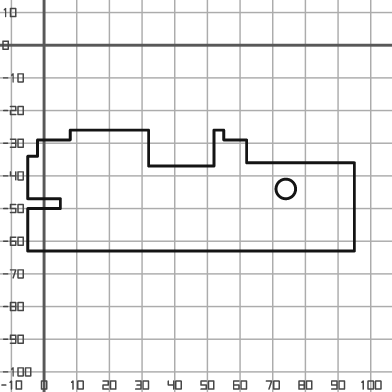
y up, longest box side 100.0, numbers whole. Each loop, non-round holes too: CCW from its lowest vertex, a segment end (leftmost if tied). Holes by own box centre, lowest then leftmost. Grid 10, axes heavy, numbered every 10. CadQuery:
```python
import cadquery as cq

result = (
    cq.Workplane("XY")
    .moveTo(-5.0, -63.0)
    .lineTo(95.0, -63.0)
    .lineTo(95.0, -36.0)
    .lineTo(62.0, -36.0)
    .lineTo(62.0, -29.0)
    .lineTo(55.0, -29.0)
    .lineTo(55.0, -26.0)
    .lineTo(52.0, -26.0)
    .lineTo(52.0, -37.0)
    .lineTo(32.0, -37.0)
    .lineTo(32.0, -26.0)
    .lineTo(8.0, -26.0)
    .lineTo(8.0, -29.0)
    .lineTo(-2.0, -29.0)
    .lineTo(-2.0, -34.0)
    .lineTo(-5.0, -34.0)
    .lineTo(-5.0, -47.0)
    .lineTo(5.0, -47.0)
    .lineTo(5.0, -50.0)
    .lineTo(-5.0, -50.0)
    .close()
    .moveTo(74.0, -44.0)
    .circle(3.0)
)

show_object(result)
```